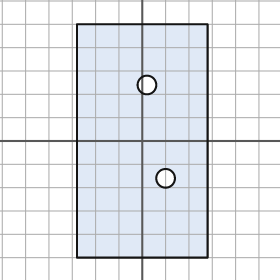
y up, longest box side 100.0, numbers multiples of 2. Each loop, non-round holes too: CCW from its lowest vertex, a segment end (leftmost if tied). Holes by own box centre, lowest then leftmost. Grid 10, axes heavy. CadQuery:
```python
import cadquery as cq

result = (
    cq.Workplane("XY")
    .moveTo(-28.0, -50.0)
    .lineTo(28.0, -50.0)
    .lineTo(28.0, 50.0)
    .lineTo(-28.0, 50.0)
    .close()
    .moveTo(10.0, -16.0)
    .circle(4.0)
    .moveTo(2.0, 24.0)
    .circle(4.0)
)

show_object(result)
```